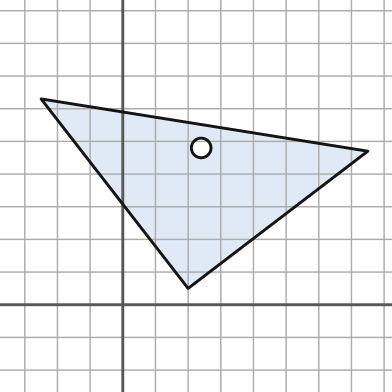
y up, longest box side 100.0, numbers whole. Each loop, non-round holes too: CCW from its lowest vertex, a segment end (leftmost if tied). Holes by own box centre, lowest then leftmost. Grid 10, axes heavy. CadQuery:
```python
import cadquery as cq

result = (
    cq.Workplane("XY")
    .moveTo(20.0, 5.0)
    .lineTo(75.0, 47.0)
    .lineTo(-25.0, 63.0)
    .close()
    .moveTo(24.0, 48.0)
    .circle(3.0)
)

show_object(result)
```